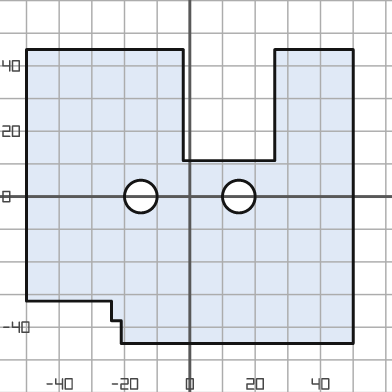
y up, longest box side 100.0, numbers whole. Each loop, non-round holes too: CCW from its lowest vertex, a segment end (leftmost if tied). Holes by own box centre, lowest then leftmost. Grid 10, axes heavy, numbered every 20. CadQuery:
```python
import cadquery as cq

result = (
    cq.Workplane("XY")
    .moveTo(-21.0, -45.0)
    .lineTo(50.0, -45.0)
    .lineTo(50.0, 45.0)
    .lineTo(26.0, 45.0)
    .lineTo(26.0, 11.0)
    .lineTo(-2.0, 11.0)
    .lineTo(-2.0, 45.0)
    .lineTo(-50.0, 45.0)
    .lineTo(-50.0, -32.0)
    .lineTo(-24.0, -32.0)
    .lineTo(-24.0, -38.0)
    .lineTo(-21.0, -38.0)
    .close()
    .moveTo(-15.0, 0.0)
    .circle(5.0)
    .moveTo(15.0, 0.0)
    .circle(5.0)
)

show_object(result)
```